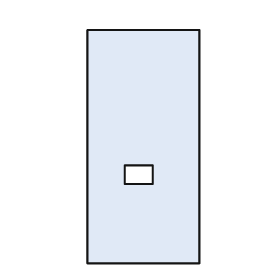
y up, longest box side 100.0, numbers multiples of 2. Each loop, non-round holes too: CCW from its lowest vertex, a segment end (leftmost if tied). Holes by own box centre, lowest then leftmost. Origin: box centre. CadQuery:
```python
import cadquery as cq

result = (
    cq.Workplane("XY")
    .moveTo(-24.0, -50.0)
    .lineTo(24.0, -50.0)
    .lineTo(24.0, 50.0)
    .lineTo(-24.0, 50.0)
    .close()
    .moveTo(-8.0, -16.0)
    .lineTo(4.0, -16.0)
    .lineTo(4.0, -8.0)
    .lineTo(-8.0, -8.0)
    .close()
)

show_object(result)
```